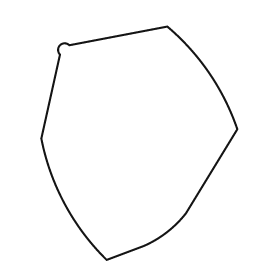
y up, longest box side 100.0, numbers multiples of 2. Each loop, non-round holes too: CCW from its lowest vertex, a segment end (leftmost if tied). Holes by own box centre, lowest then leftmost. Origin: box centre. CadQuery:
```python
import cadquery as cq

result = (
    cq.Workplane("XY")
    .moveTo(-14.0, -50.0)
    .lineTo(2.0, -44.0)
    .threePointArc((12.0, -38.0), (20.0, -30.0))
    .lineTo(42.0, 6.0)
    .threePointArc((30.0, 30.0), (12.0, 50.0))
    .lineTo(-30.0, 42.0)
    .threePointArc((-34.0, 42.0), (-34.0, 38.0))
    .lineTo(-42.0, 2.0)
    .threePointArc((-32.0, -26.0), (-14.0, -50.0))
    .close()
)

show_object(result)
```